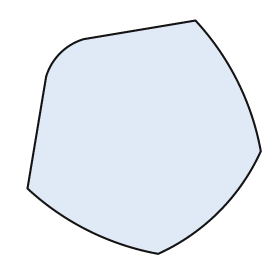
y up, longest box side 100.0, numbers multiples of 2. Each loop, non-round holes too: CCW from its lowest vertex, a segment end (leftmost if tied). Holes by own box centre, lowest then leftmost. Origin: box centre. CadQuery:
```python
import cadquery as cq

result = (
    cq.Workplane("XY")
    .moveTo(6.0, -50.0)
    .threePointArc((32.0, -32.0), (50.0, -6.0))
    .threePointArc((40.0, 24.0), (22.0, 50.0))
    .lineTo(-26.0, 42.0)
    .threePointArc((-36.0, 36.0), (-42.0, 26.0))
    .lineTo(-50.0, -22.0)
    .threePointArc((-24.0, -40.0), (6.0, -50.0))
    .close()
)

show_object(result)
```